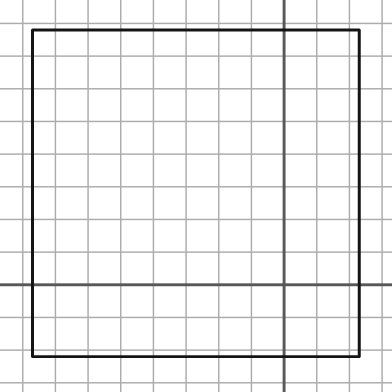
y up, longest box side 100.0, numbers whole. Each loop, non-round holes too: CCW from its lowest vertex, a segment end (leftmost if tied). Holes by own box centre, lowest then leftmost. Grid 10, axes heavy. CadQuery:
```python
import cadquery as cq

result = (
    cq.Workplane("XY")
    .moveTo(-77.0, -22.0)
    .lineTo(23.0, -22.0)
    .lineTo(23.0, 78.0)
    .lineTo(-77.0, 78.0)
    .close()
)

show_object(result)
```